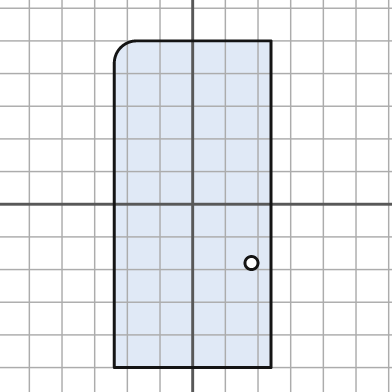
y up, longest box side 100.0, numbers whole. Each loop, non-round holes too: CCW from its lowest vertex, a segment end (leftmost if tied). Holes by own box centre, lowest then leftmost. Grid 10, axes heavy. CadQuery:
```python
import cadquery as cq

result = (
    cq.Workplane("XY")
    .moveTo(-24.0, -50.0)
    .lineTo(24.0, -50.0)
    .lineTo(24.0, 50.0)
    .lineTo(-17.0, 50.0)
    .threePointArc((-22.0, 48.0), (-24.0, 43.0))
    .close()
    .moveTo(18.0, -18.0)
    .circle(2.0)
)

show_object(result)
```